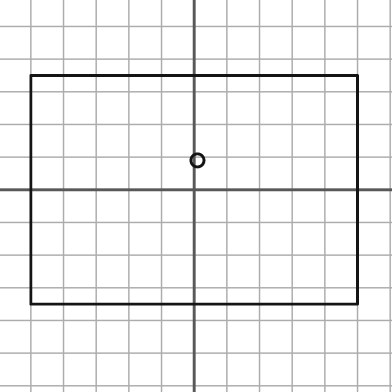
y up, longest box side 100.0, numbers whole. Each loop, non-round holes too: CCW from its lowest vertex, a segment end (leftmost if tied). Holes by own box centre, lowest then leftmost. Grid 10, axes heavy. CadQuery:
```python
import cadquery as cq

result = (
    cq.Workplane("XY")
    .moveTo(-50.0, -35.0)
    .lineTo(50.0, -35.0)
    .lineTo(50.0, 35.0)
    .lineTo(-50.0, 35.0)
    .close()
    .moveTo(1.0, 9.0)
    .circle(2.0)
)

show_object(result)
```